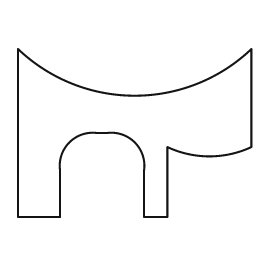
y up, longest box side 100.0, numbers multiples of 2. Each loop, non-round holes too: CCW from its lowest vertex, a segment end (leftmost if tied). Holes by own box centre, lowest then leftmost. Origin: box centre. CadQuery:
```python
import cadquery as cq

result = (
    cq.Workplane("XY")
    .moveTo(-50.0, -36.0)
    .lineTo(-32.0, -36.0)
    .lineTo(-32.0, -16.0)
    .threePointArc((-28.0, -4.0), (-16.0, 0.0))
    .lineTo(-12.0, 0.0)
    .threePointArc((0.0, -4.0), (4.0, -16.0))
    .lineTo(4.0, -36.0)
    .lineTo(14.0, -36.0)
    .lineTo(14.0, -6.0)
    .threePointArc((32.0, -10.0), (50.0, -6.0))
    .lineTo(50.0, 36.0)
    .threePointArc((0.0, 16.0), (-50.0, 36.0))
    .close()
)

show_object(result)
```